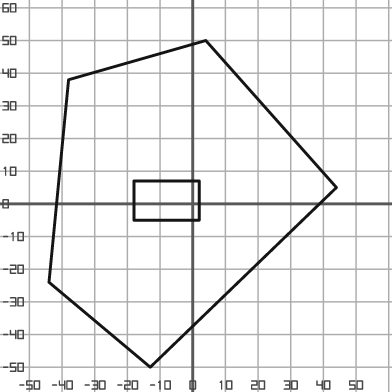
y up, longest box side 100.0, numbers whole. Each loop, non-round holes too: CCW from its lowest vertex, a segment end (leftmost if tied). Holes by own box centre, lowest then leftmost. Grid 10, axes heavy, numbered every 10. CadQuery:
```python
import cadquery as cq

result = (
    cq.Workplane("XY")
    .moveTo(-13.0, -50.0)
    .lineTo(44.0, 5.0)
    .lineTo(4.0, 50.0)
    .lineTo(-38.0, 38.0)
    .lineTo(-44.0, -24.0)
    .close()
    .moveTo(-18.0, -5.0)
    .lineTo(2.0, -5.0)
    .lineTo(2.0, 7.0)
    .lineTo(-18.0, 7.0)
    .close()
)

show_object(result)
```